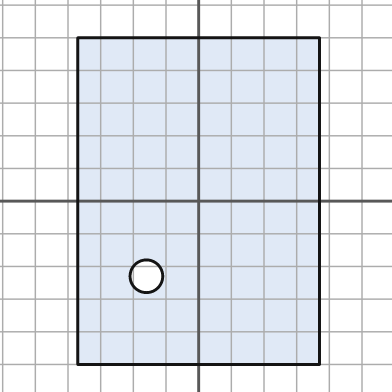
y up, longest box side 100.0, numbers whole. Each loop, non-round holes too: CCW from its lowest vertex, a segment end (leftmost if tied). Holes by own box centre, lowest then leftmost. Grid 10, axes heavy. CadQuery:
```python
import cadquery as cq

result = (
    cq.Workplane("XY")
    .moveTo(-37.0, -50.0)
    .lineTo(37.0, -50.0)
    .lineTo(37.0, 50.0)
    .lineTo(-37.0, 50.0)
    .close()
    .moveTo(-16.0, -23.0)
    .circle(5.0)
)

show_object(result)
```